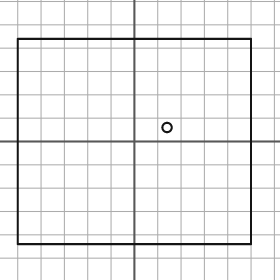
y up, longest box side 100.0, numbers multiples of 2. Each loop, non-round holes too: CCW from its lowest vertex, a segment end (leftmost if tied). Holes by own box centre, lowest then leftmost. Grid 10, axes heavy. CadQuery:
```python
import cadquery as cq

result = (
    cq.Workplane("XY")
    .moveTo(-50.0, -44.0)
    .lineTo(50.0, -44.0)
    .lineTo(50.0, 44.0)
    .lineTo(-50.0, 44.0)
    .close()
    .moveTo(14.0, 6.0)
    .circle(2.0)
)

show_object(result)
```